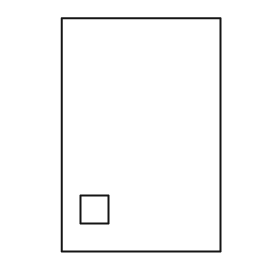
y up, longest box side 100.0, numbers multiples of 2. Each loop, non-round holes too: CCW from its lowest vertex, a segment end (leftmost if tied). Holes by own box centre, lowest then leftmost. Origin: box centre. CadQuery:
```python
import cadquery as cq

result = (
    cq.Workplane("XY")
    .moveTo(-34.0, -50.0)
    .lineTo(34.0, -50.0)
    .lineTo(34.0, 50.0)
    .lineTo(-34.0, 50.0)
    .close()
    .moveTo(-26.0, -38.0)
    .lineTo(-14.0, -38.0)
    .lineTo(-14.0, -26.0)
    .lineTo(-26.0, -26.0)
    .close()
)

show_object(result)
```